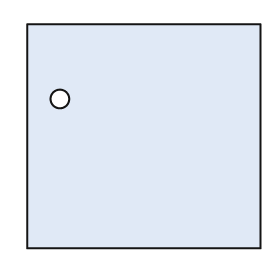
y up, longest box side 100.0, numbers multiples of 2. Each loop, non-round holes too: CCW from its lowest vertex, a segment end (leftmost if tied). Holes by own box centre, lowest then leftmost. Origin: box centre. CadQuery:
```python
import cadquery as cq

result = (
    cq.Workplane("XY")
    .moveTo(-50.0, -48.0)
    .lineTo(50.0, -48.0)
    .lineTo(50.0, 48.0)
    .lineTo(-50.0, 48.0)
    .close()
    .moveTo(-36.0, 16.0)
    .circle(4.0)
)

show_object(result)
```